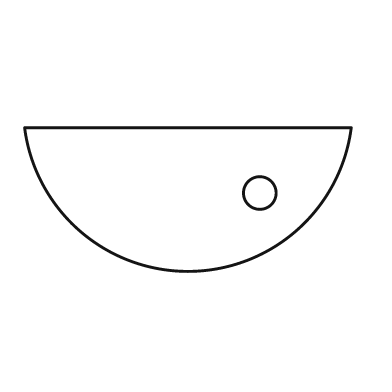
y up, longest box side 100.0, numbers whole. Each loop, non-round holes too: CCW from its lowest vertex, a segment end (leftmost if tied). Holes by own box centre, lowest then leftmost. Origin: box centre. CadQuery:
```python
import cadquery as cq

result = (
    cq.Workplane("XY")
    .moveTo(-50.0, 22.0)
    .threePointArc((0.0, -22.0), (50.0, 22.0))
    .close()
    .moveTo(22.0, 2.0)
    .circle(5.0)
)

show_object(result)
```